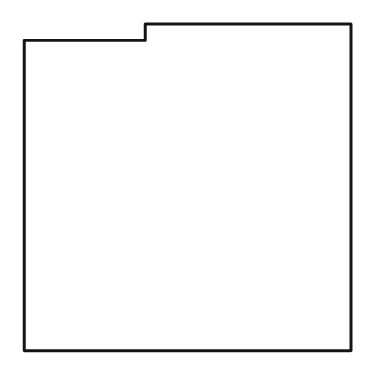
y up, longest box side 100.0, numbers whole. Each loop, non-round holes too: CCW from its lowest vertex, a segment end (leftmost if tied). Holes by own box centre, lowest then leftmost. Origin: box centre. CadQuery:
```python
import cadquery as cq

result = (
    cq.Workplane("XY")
    .moveTo(-50.0, -50.0)
    .lineTo(50.0, -50.0)
    .lineTo(50.0, 50.0)
    .lineTo(-13.0, 50.0)
    .lineTo(-13.0, 45.0)
    .lineTo(-50.0, 45.0)
    .close()
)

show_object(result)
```